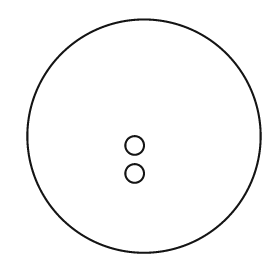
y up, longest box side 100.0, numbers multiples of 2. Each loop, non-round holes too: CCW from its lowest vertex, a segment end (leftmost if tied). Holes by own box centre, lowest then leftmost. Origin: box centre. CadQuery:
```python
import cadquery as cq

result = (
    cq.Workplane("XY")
    .moveTo(0.0, 0.0)
    .circle(50.0)
    .moveTo(-4.0, -16.0)
    .circle(4.0)
    .moveTo(-4.0, -4.0)
    .circle(4.0)
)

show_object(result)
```